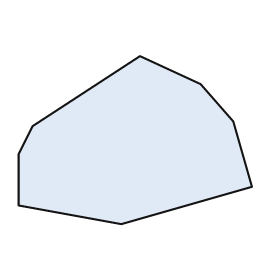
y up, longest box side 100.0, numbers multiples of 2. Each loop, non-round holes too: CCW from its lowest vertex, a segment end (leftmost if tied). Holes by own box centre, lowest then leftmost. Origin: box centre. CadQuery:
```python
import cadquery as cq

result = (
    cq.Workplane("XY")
    .moveTo(-6.0, -36.0)
    .lineTo(50.0, -20.0)
    .lineTo(42.0, 8.0)
    .lineTo(28.0, 24.0)
    .lineTo(2.0, 36.0)
    .lineTo(-44.0, 6.0)
    .lineTo(-50.0, -6.0)
    .lineTo(-50.0, -28.0)
    .close()
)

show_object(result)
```